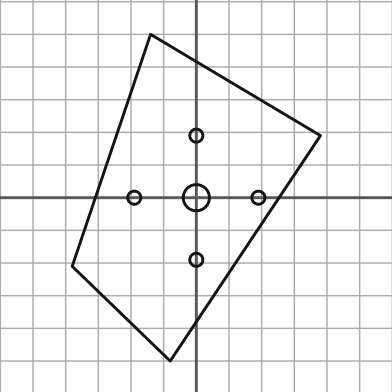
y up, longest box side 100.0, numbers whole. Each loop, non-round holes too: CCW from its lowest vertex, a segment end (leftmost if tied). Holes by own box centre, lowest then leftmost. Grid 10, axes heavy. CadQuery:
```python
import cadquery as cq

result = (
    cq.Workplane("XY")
    .moveTo(-8.0, -50.0)
    .lineTo(38.0, 19.0)
    .lineTo(-14.0, 50.0)
    .lineTo(-38.0, -21.0)
    .close()
    .moveTo(0.0, -19.0)
    .circle(2.0)
    .moveTo(-19.0, 0.0)
    .circle(2.0)
    .moveTo(0.0, 0.0)
    .circle(4.0)
    .moveTo(19.0, 0.0)
    .circle(2.0)
    .moveTo(0.0, 19.0)
    .circle(2.0)
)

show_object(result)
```